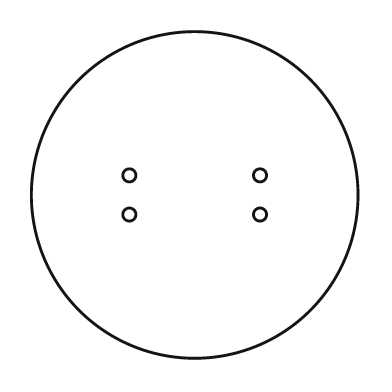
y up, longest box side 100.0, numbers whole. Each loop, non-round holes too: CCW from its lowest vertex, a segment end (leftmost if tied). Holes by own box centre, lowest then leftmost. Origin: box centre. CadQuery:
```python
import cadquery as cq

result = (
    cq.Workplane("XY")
    .moveTo(0.0, 0.0)
    .circle(50.0)
    .moveTo(-20.0, -6.0)
    .circle(2.0)
    .moveTo(20.0, -6.0)
    .circle(2.0)
    .moveTo(-20.0, 6.0)
    .circle(2.0)
    .moveTo(20.0, 6.0)
    .circle(2.0)
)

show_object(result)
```